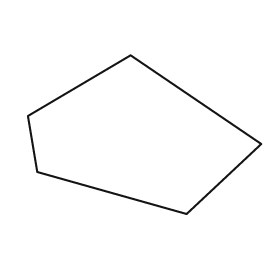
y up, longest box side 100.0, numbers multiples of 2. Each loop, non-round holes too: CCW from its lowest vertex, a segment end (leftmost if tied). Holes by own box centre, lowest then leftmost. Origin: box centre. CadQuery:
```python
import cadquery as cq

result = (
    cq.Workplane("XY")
    .moveTo(18.0, -34.0)
    .lineTo(50.0, -4.0)
    .lineTo(-6.0, 34.0)
    .lineTo(-50.0, 8.0)
    .lineTo(-46.0, -16.0)
    .close()
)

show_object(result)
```